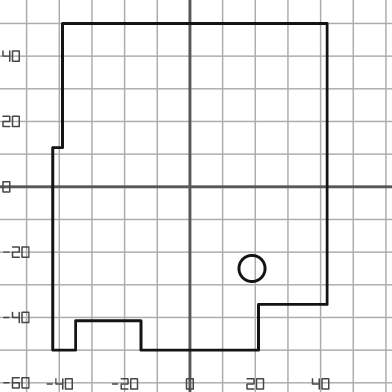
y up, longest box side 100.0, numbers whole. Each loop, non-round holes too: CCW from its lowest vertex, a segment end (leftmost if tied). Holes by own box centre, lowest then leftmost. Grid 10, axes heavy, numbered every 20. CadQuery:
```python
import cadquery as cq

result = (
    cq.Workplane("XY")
    .moveTo(-42.0, -50.0)
    .lineTo(-35.0, -50.0)
    .lineTo(-35.0, -41.0)
    .lineTo(-15.0, -41.0)
    .lineTo(-15.0, -50.0)
    .lineTo(21.0, -50.0)
    .lineTo(21.0, -36.0)
    .lineTo(42.0, -36.0)
    .lineTo(42.0, 50.0)
    .lineTo(-39.0, 50.0)
    .lineTo(-39.0, 12.0)
    .lineTo(-42.0, 12.0)
    .close()
    .moveTo(19.0, -25.0)
    .circle(4.0)
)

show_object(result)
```